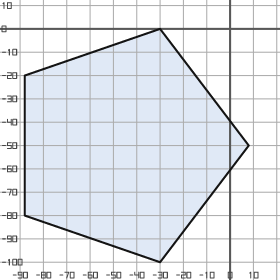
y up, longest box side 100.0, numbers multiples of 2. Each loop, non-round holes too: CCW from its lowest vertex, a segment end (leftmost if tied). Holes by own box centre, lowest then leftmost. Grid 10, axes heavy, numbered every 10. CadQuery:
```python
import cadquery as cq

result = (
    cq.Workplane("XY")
    .moveTo(-30.0, -100.0)
    .lineTo(8.0, -50.0)
    .lineTo(-30.0, 0.0)
    .lineTo(-88.0, -20.0)
    .lineTo(-88.0, -80.0)
    .close()
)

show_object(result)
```